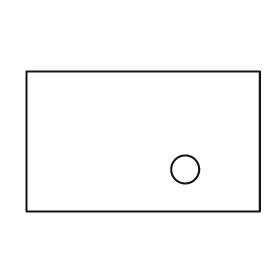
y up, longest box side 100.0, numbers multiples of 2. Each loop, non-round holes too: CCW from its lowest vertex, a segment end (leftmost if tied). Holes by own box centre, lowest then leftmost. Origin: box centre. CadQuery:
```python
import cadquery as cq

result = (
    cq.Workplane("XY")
    .moveTo(-50.0, -30.0)
    .lineTo(50.0, -30.0)
    .lineTo(50.0, 30.0)
    .lineTo(-50.0, 30.0)
    .close()
    .moveTo(18.0, -12.0)
    .circle(6.0)
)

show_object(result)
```